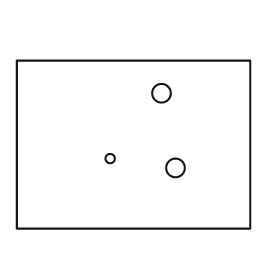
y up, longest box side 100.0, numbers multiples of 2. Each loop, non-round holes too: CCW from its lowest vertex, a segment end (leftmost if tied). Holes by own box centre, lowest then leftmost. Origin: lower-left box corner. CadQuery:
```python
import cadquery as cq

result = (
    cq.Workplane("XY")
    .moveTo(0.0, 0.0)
    .lineTo(100.0, 0.0)
    .lineTo(100.0, 72.0)
    .lineTo(0.0, 72.0)
    .close()
    .moveTo(68.0, 26.0)
    .circle(4.0)
    .moveTo(40.0, 30.0)
    .circle(2.0)
    .moveTo(62.0, 58.0)
    .circle(4.0)
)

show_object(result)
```